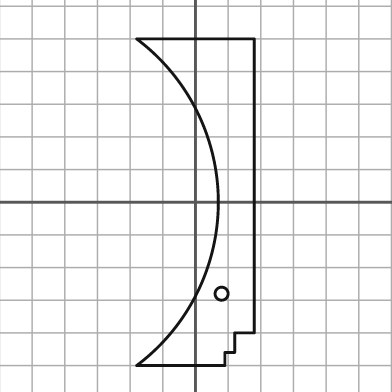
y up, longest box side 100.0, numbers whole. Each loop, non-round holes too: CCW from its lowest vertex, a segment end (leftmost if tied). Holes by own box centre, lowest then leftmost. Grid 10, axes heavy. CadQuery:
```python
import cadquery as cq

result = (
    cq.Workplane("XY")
    .moveTo(-18.0, -50.0)
    .lineTo(9.0, -50.0)
    .lineTo(9.0, -46.0)
    .lineTo(12.0, -46.0)
    .lineTo(12.0, -40.0)
    .lineTo(18.0, -40.0)
    .lineTo(18.0, 50.0)
    .lineTo(-18.0, 50.0)
    .threePointArc((7.0, 0.0), (-18.0, -50.0))
    .close()
    .moveTo(8.0, -28.0)
    .circle(2.0)
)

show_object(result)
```